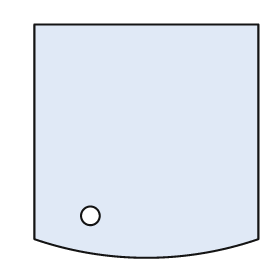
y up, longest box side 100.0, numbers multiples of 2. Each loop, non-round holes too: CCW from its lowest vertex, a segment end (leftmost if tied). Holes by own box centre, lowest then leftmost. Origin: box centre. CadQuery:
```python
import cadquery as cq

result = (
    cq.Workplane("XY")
    .moveTo(-48.0, -42.0)
    .threePointArc((0.0, -50.0), (48.0, -42.0))
    .lineTo(48.0, 50.0)
    .lineTo(-48.0, 50.0)
    .close()
    .moveTo(-24.0, -32.0)
    .circle(4.0)
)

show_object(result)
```